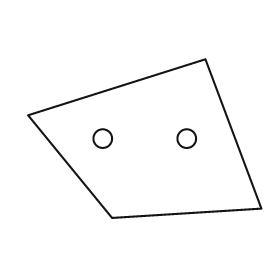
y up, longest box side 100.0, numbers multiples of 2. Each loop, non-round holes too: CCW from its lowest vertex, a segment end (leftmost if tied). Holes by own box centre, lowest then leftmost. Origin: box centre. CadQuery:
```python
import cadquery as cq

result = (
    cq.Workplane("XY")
    .moveTo(-14.0, -34.0)
    .lineTo(50.0, -30.0)
    .lineTo(26.0, 34.0)
    .lineTo(-50.0, 10.0)
    .close()
    .moveTo(-18.0, 0.0)
    .circle(4.0)
    .moveTo(18.0, 0.0)
    .circle(4.0)
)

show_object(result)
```